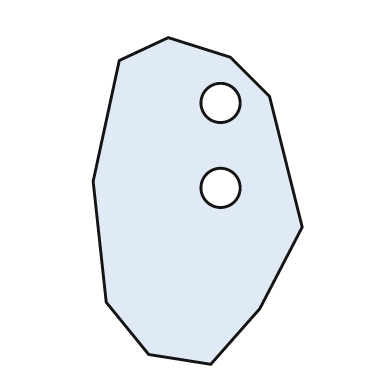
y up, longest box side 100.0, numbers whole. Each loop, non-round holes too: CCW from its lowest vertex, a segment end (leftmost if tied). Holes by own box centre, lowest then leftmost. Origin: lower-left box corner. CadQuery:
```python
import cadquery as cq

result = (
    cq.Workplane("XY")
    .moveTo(36.0, 0.0)
    .lineTo(51.0, 17.0)
    .lineTo(64.0, 42.0)
    .lineTo(54.0, 82.0)
    .lineTo(42.0, 94.0)
    .lineTo(23.0, 100.0)
    .lineTo(8.0, 93.0)
    .lineTo(0.0, 56.0)
    .lineTo(4.0, 19.0)
    .lineTo(17.0, 3.0)
    .close()
    .moveTo(39.0, 54.0)
    .circle(6.0)
    .moveTo(39.0, 80.0)
    .circle(6.0)
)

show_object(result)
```